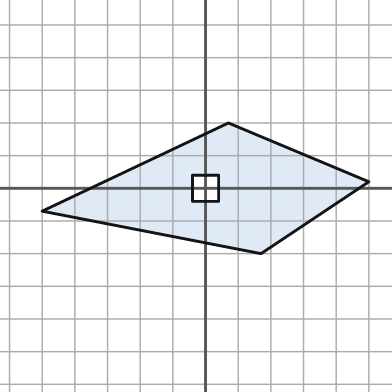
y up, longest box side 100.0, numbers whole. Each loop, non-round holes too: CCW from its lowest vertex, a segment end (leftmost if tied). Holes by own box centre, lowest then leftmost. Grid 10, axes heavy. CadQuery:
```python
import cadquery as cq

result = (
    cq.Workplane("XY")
    .moveTo(17.0, -20.0)
    .lineTo(50.0, 2.0)
    .lineTo(7.0, 20.0)
    .lineTo(-50.0, -7.0)
    .close()
    .moveTo(-4.0, -4.0)
    .lineTo(4.0, -4.0)
    .lineTo(4.0, 4.0)
    .lineTo(-4.0, 4.0)
    .close()
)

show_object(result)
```